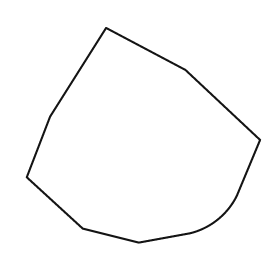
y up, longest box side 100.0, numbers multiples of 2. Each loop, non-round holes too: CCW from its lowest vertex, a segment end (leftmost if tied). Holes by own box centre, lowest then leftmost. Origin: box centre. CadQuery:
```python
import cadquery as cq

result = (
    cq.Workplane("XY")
    .moveTo(-2.0, -46.0)
    .lineTo(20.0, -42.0)
    .threePointArc((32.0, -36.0), (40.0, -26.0))
    .lineTo(50.0, -2.0)
    .lineTo(18.0, 28.0)
    .lineTo(-16.0, 46.0)
    .lineTo(-40.0, 8.0)
    .lineTo(-50.0, -18.0)
    .lineTo(-26.0, -40.0)
    .close()
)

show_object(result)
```